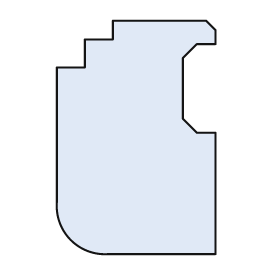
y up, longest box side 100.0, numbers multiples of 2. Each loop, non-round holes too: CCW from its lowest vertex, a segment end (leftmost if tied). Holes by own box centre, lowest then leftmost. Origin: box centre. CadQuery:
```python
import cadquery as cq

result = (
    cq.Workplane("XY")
    .moveTo(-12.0, -50.0)
    .lineTo(34.0, -50.0)
    .lineTo(34.0, 2.0)
    .lineTo(26.0, 2.0)
    .lineTo(20.0, 8.0)
    .lineTo(20.0, 34.0)
    .lineTo(26.0, 40.0)
    .lineTo(34.0, 40.0)
    .lineTo(34.0, 46.0)
    .lineTo(30.0, 50.0)
    .lineTo(-10.0, 50.0)
    .lineTo(-10.0, 42.0)
    .lineTo(-22.0, 42.0)
    .lineTo(-22.0, 30.0)
    .lineTo(-34.0, 30.0)
    .lineTo(-34.0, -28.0)
    .threePointArc((-28.0, -44.0), (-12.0, -50.0))
    .close()
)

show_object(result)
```